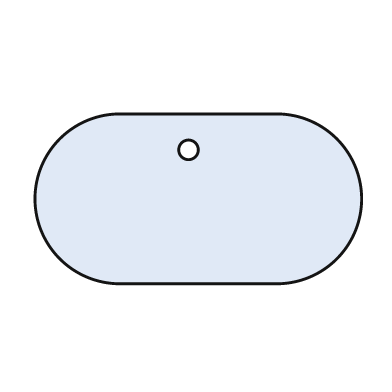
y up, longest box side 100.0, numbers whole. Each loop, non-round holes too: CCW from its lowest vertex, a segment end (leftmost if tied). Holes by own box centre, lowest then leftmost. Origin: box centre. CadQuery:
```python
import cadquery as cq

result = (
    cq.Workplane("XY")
    .moveTo(-24.0, -26.0)
    .lineTo(24.0, -26.0)
    .threePointArc((50.0, 0.0), (24.0, 26.0))
    .lineTo(-24.0, 26.0)
    .threePointArc((-50.0, 0.0), (-24.0, -26.0))
    .close()
    .moveTo(-3.0, 15.0)
    .circle(3.0)
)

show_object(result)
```